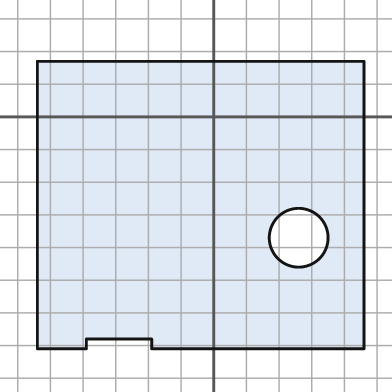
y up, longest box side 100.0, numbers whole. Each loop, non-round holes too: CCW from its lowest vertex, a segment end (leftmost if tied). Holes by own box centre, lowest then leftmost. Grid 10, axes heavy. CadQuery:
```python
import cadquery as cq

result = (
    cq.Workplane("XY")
    .moveTo(-54.0, -71.0)
    .lineTo(-39.0, -71.0)
    .lineTo(-39.0, -68.0)
    .lineTo(-19.0, -68.0)
    .lineTo(-19.0, -71.0)
    .lineTo(46.0, -71.0)
    .lineTo(46.0, 17.0)
    .lineTo(-54.0, 17.0)
    .close()
    .moveTo(26.0, -37.0)
    .circle(9.0)
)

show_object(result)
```